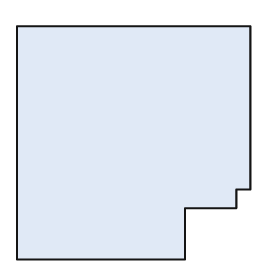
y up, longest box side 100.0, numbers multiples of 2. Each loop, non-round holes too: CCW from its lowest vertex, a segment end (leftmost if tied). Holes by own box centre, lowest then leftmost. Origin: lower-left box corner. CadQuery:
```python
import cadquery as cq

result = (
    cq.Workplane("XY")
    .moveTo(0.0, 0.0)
    .lineTo(72.0, 0.0)
    .lineTo(72.0, 22.0)
    .lineTo(94.0, 22.0)
    .lineTo(94.0, 30.0)
    .lineTo(100.0, 30.0)
    .lineTo(100.0, 100.0)
    .lineTo(0.0, 100.0)
    .close()
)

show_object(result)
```